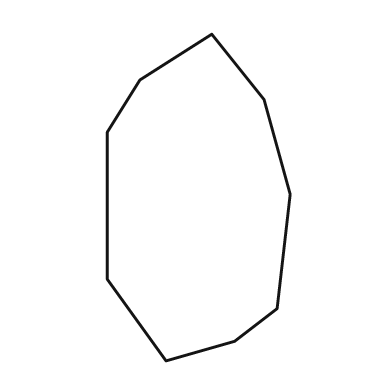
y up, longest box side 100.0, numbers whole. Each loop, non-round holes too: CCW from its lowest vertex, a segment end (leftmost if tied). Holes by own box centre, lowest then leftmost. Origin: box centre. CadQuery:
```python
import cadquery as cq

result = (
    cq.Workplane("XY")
    .moveTo(-10.0, -50.0)
    .lineTo(11.0, -44.0)
    .lineTo(24.0, -34.0)
    .lineTo(28.0, 1.0)
    .lineTo(20.0, 30.0)
    .lineTo(4.0, 50.0)
    .lineTo(-18.0, 36.0)
    .lineTo(-28.0, 20.0)
    .lineTo(-28.0, -25.0)
    .close()
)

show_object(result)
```